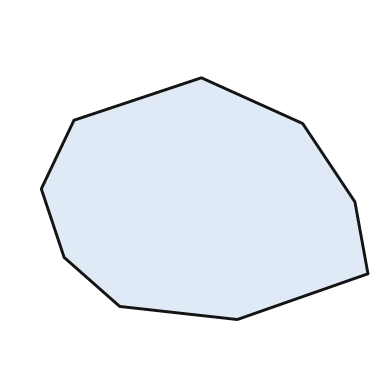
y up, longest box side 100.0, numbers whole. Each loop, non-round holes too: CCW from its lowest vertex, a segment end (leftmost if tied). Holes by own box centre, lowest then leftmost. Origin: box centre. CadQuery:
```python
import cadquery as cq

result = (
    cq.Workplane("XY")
    .moveTo(10.0, -37.0)
    .lineTo(50.0, -23.0)
    .lineTo(46.0, -1.0)
    .lineTo(30.0, 23.0)
    .lineTo(-1.0, 37.0)
    .lineTo(-40.0, 24.0)
    .lineTo(-50.0, 3.0)
    .lineTo(-43.0, -18.0)
    .lineTo(-26.0, -33.0)
    .close()
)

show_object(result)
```